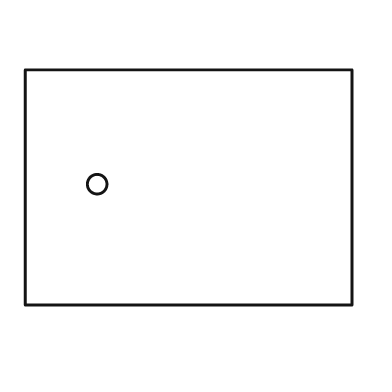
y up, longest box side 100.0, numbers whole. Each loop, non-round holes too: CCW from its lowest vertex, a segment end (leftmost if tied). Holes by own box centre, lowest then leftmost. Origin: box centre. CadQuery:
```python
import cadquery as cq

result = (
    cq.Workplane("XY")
    .moveTo(-50.0, -36.0)
    .lineTo(50.0, -36.0)
    .lineTo(50.0, 36.0)
    .lineTo(-50.0, 36.0)
    .close()
    .moveTo(-28.0, 1.0)
    .circle(3.0)
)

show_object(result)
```